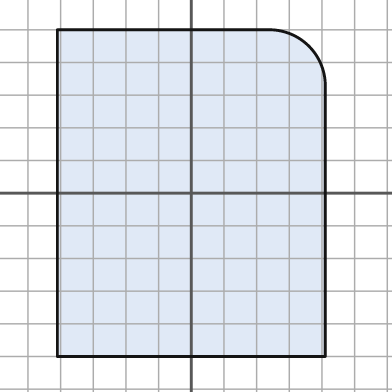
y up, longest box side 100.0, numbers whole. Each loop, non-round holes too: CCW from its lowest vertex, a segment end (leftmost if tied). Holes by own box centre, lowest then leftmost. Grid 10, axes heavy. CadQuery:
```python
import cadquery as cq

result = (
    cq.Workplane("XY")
    .moveTo(-41.0, -50.0)
    .lineTo(41.0, -50.0)
    .lineTo(41.0, 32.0)
    .threePointArc((36.0, 45.0), (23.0, 50.0))
    .lineTo(-41.0, 50.0)
    .close()
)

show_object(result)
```